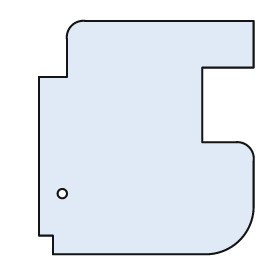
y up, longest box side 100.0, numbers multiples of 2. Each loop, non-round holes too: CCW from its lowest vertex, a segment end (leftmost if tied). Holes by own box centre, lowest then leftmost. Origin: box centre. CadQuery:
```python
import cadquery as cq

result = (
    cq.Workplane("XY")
    .moveTo(-40.0, -50.0)
    .lineTo(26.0, -50.0)
    .threePointArc((40.0, -44.0), (46.0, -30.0))
    .lineTo(46.0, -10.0)
    .threePointArc((44.0, -4.0), (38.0, -2.0))
    .lineTo(24.0, -2.0)
    .lineTo(24.0, 30.0)
    .lineTo(46.0, 30.0)
    .lineTo(46.0, 50.0)
    .lineTo(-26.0, 50.0)
    .threePointArc((-32.0, 48.0), (-34.0, 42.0))
    .lineTo(-34.0, 26.0)
    .lineTo(-46.0, 26.0)
    .lineTo(-46.0, -42.0)
    .lineTo(-40.0, -42.0)
    .close()
    .moveTo(-36.0, -24.0)
    .circle(2.0)
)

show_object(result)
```